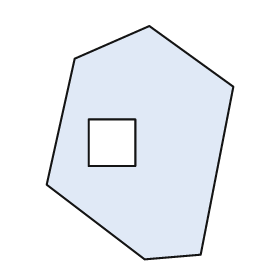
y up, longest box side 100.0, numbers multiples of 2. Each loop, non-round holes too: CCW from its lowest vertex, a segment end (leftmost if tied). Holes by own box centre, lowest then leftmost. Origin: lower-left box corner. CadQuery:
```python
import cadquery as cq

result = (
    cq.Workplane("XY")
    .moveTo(42.0, 0.0)
    .lineTo(66.0, 2.0)
    .lineTo(80.0, 74.0)
    .lineTo(44.0, 100.0)
    .lineTo(12.0, 86.0)
    .lineTo(0.0, 32.0)
    .close()
    .moveTo(18.0, 40.0)
    .lineTo(38.0, 40.0)
    .lineTo(38.0, 60.0)
    .lineTo(18.0, 60.0)
    .close()
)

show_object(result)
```